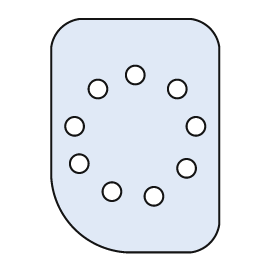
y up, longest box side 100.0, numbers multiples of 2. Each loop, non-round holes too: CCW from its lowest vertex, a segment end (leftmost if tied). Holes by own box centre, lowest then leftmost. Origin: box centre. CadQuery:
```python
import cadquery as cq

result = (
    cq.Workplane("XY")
    .moveTo(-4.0, -50.0)
    .lineTo(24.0, -50.0)
    .threePointArc((32.0, -46.0), (36.0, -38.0))
    .lineTo(36.0, 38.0)
    .threePointArc((32.0, 46.0), (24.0, 50.0))
    .lineTo(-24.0, 50.0)
    .threePointArc((-32.0, 46.0), (-36.0, 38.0))
    .lineTo(-36.0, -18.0)
    .threePointArc((-26.0, -40.0), (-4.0, -50.0))
    .close()
    .moveTo(8.0, -26.0)
    .circle(4.0)
    .moveTo(-10.0, -24.0)
    .circle(4.0)
    .moveTo(22.0, -14.0)
    .circle(4.0)
    .moveTo(-24.0, -12.0)
    .circle(4.0)
    .moveTo(-26.0, 4.0)
    .circle(4.0)
    .moveTo(26.0, 4.0)
    .circle(4.0)
    .moveTo(-16.0, 20.0)
    .circle(4.0)
    .moveTo(18.0, 20.0)
    .circle(4.0)
    .moveTo(0.0, 26.0)
    .circle(4.0)
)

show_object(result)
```